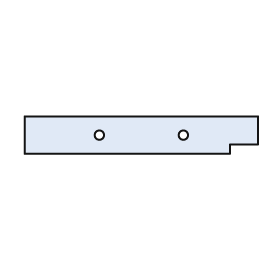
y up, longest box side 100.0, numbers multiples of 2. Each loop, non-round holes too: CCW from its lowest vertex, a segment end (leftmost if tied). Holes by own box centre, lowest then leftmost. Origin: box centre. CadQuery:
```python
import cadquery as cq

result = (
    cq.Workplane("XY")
    .moveTo(-50.0, -8.0)
    .lineTo(38.0, -8.0)
    .lineTo(38.0, -4.0)
    .lineTo(50.0, -4.0)
    .lineTo(50.0, 8.0)
    .lineTo(-50.0, 8.0)
    .close()
    .moveTo(-18.0, 0.0)
    .circle(2.0)
    .moveTo(18.0, 0.0)
    .circle(2.0)
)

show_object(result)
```